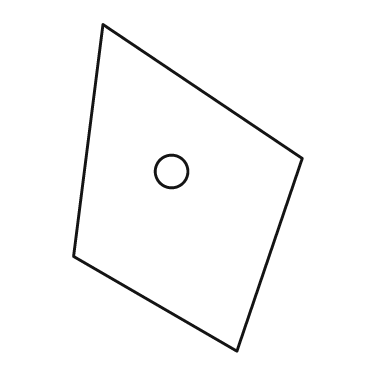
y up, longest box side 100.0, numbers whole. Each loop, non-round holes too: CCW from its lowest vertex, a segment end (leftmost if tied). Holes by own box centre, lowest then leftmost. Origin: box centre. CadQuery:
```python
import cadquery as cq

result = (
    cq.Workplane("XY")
    .moveTo(15.0, -50.0)
    .lineTo(35.0, 9.0)
    .lineTo(-26.0, 50.0)
    .lineTo(-35.0, -21.0)
    .close()
    .moveTo(-5.0, 5.0)
    .circle(5.0)
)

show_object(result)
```